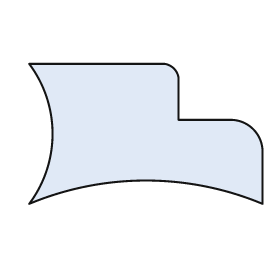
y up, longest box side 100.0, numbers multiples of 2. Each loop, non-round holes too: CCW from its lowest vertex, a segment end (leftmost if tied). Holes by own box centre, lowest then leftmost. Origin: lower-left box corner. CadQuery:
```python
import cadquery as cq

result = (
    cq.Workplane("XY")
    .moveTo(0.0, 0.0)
    .threePointArc((50.0, 10.0), (100.0, 0.0))
    .lineTo(100.0, 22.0)
    .threePointArc((96.0, 32.0), (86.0, 36.0))
    .lineTo(64.0, 36.0)
    .lineTo(64.0, 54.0)
    .threePointArc((62.0, 58.0), (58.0, 60.0))
    .lineTo(0.0, 60.0)
    .threePointArc((10.0, 30.0), (0.0, 0.0))
    .close()
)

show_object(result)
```